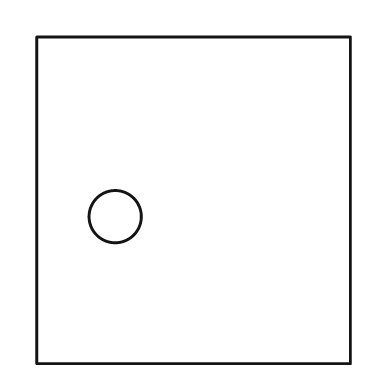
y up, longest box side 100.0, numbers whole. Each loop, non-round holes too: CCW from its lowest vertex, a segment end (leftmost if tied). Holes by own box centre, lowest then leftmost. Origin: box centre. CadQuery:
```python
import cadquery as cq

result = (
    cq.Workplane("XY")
    .moveTo(-48.0, -50.0)
    .lineTo(48.0, -50.0)
    .lineTo(48.0, 50.0)
    .lineTo(-48.0, 50.0)
    .close()
    .moveTo(-24.0, -5.0)
    .circle(8.0)
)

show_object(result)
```